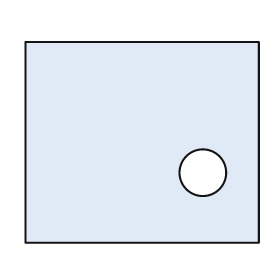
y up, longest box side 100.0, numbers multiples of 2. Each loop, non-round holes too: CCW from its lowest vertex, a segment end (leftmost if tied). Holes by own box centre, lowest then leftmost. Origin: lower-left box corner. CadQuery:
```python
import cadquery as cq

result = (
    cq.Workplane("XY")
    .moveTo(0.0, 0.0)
    .lineTo(100.0, 0.0)
    .lineTo(100.0, 86.0)
    .lineTo(0.0, 86.0)
    .close()
    .moveTo(76.0, 30.0)
    .circle(10.0)
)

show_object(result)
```